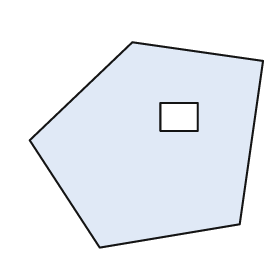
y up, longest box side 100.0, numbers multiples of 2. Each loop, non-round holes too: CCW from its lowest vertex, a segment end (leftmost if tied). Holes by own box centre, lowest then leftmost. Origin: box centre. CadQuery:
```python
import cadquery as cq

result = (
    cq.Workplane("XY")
    .moveTo(-20.0, -44.0)
    .lineTo(40.0, -34.0)
    .lineTo(50.0, 36.0)
    .lineTo(-6.0, 44.0)
    .lineTo(-50.0, 2.0)
    .close()
    .moveTo(6.0, 6.0)
    .lineTo(22.0, 6.0)
    .lineTo(22.0, 18.0)
    .lineTo(6.0, 18.0)
    .close()
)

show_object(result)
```